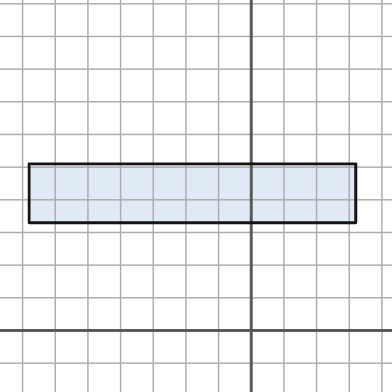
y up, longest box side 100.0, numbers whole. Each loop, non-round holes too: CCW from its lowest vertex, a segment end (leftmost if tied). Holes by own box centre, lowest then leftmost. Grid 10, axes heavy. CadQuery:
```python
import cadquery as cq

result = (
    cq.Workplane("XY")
    .moveTo(-68.0, 33.0)
    .lineTo(32.0, 33.0)
    .lineTo(32.0, 51.0)
    .lineTo(-68.0, 51.0)
    .close()
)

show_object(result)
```